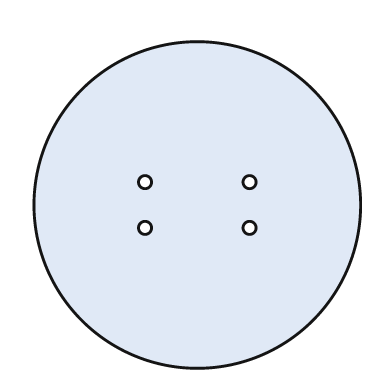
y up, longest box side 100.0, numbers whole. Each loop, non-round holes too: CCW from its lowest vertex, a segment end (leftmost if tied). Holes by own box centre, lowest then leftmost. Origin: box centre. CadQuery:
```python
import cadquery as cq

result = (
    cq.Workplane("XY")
    .moveTo(0.0, 0.0)
    .circle(50.0)
    .moveTo(-16.0, -7.0)
    .circle(2.0)
    .moveTo(16.0, -7.0)
    .circle(2.0)
    .moveTo(-16.0, 7.0)
    .circle(2.0)
    .moveTo(16.0, 7.0)
    .circle(2.0)
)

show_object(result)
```